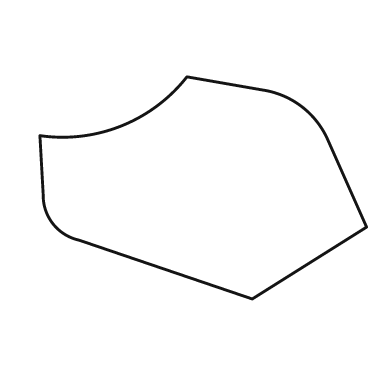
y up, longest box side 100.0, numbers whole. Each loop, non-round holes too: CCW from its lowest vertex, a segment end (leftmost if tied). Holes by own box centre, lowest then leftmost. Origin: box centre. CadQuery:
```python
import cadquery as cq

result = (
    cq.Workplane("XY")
    .moveTo(15.0, -34.0)
    .lineTo(50.0, -12.0)
    .lineTo(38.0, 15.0)
    .threePointArc((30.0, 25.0), (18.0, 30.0))
    .lineTo(-5.0, 34.0)
    .threePointArc((-25.0, 19.0), (-50.0, 16.0))
    .lineTo(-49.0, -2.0)
    .threePointArc((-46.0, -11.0), (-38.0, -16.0))
    .close()
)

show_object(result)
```